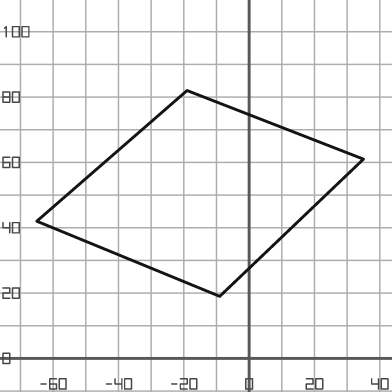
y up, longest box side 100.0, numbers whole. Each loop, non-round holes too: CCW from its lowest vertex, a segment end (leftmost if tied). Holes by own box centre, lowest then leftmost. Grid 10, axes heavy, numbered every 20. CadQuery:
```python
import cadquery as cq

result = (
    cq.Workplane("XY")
    .moveTo(-9.0, 19.0)
    .lineTo(35.0, 61.0)
    .lineTo(-19.0, 82.0)
    .lineTo(-65.0, 42.0)
    .close()
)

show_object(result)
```